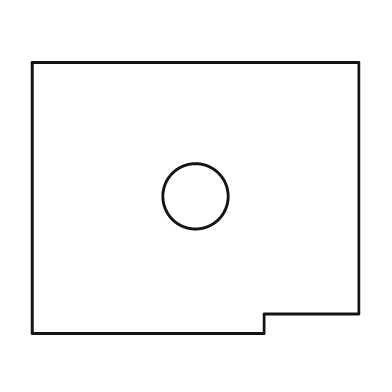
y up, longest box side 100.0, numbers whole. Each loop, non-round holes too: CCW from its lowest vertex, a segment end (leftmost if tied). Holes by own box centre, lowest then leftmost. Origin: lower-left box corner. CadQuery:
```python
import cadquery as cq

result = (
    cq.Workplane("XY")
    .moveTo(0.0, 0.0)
    .lineTo(71.0, 0.0)
    .lineTo(71.0, 6.0)
    .lineTo(100.0, 6.0)
    .lineTo(100.0, 83.0)
    .lineTo(0.0, 83.0)
    .close()
    .moveTo(50.0, 42.0)
    .circle(10.0)
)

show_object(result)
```